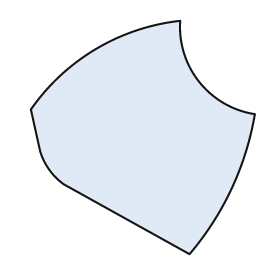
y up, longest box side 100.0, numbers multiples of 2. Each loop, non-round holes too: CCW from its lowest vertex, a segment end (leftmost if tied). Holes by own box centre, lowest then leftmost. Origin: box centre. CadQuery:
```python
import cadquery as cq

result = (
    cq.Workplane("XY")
    .moveTo(20.0, -50.0)
    .threePointArc((38.0, -22.0), (48.0, 10.0))
    .threePointArc((24.0, 24.0), (16.0, 50.0))
    .threePointArc((-20.0, 38.0), (-48.0, 12.0))
    .lineTo(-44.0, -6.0)
    .threePointArc((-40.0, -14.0), (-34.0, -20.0))
    .close()
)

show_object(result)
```